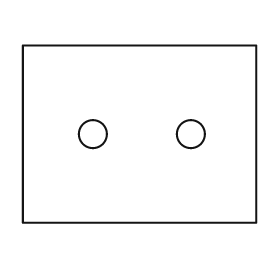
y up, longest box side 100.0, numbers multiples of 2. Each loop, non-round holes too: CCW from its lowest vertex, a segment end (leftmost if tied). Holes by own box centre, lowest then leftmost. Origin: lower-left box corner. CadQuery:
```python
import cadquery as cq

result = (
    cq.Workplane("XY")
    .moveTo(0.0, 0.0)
    .lineTo(100.0, 0.0)
    .lineTo(100.0, 76.0)
    .lineTo(0.0, 76.0)
    .close()
    .moveTo(30.0, 38.0)
    .circle(6.0)
    .moveTo(72.0, 38.0)
    .circle(6.0)
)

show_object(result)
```